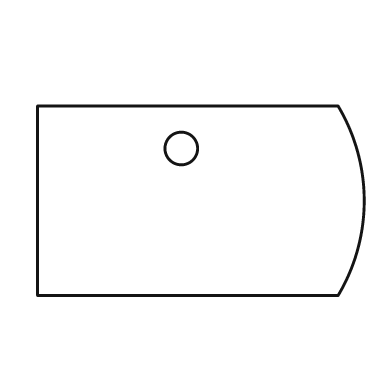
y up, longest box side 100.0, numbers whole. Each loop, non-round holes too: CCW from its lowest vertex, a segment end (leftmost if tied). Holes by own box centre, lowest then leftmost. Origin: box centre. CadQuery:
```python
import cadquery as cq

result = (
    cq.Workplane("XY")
    .moveTo(-50.0, -29.0)
    .lineTo(42.0, -29.0)
    .threePointArc((50.0, 0.0), (42.0, 29.0))
    .lineTo(-50.0, 29.0)
    .close()
    .moveTo(-6.0, 16.0)
    .circle(5.0)
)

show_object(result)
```